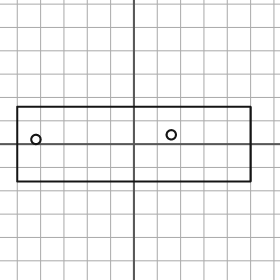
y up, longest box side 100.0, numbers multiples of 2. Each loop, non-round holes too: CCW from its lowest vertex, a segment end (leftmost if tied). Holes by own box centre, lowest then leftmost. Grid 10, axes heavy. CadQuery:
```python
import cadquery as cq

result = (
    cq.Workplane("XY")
    .moveTo(-50.0, -16.0)
    .lineTo(50.0, -16.0)
    .lineTo(50.0, 16.0)
    .lineTo(-50.0, 16.0)
    .close()
    .moveTo(-42.0, 2.0)
    .circle(2.0)
    .moveTo(16.0, 4.0)
    .circle(2.0)
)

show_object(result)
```